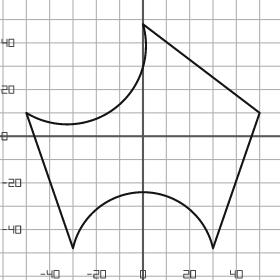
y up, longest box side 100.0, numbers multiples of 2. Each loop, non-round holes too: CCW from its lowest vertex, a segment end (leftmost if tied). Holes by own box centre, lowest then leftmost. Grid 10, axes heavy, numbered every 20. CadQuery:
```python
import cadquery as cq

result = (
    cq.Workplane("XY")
    .moveTo(-30.0, -48.0)
    .threePointArc((0.0, -24.0), (30.0, -48.0))
    .lineTo(50.0, 10.0)
    .lineTo(0.0, 48.0)
    .threePointArc((-12.0, 12.0), (-50.0, 10.0))
    .close()
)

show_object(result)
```